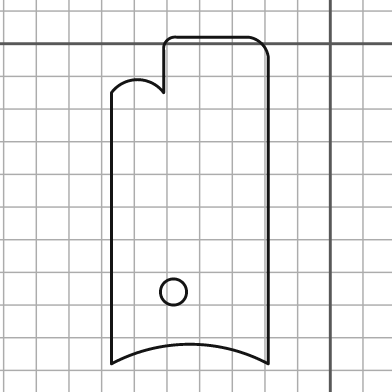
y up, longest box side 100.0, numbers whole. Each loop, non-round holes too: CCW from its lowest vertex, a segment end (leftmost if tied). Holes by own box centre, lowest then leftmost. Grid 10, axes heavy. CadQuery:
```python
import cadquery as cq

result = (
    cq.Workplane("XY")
    .moveTo(-67.0, -98.0)
    .threePointArc((-43.0, -92.0), (-19.0, -98.0))
    .lineTo(-19.0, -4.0)
    .threePointArc((-21.0, 0.0), (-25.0, 2.0))
    .lineTo(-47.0, 2.0)
    .threePointArc((-50.0, 1.0), (-51.0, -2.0))
    .lineTo(-51.0, -15.0)
    .threePointArc((-59.0, -11.0), (-67.0, -15.0))
    .close()
    .moveTo(-48.0, -76.0)
    .circle(4.0)
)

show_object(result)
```